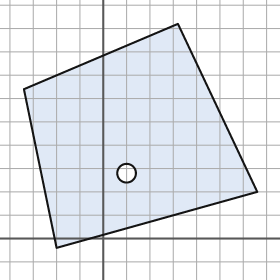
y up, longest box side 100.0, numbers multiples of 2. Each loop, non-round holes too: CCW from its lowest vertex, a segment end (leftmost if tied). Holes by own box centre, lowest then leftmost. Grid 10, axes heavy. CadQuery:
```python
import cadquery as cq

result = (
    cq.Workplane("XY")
    .moveTo(-20.0, -4.0)
    .lineTo(66.0, 20.0)
    .lineTo(32.0, 92.0)
    .lineTo(-34.0, 64.0)
    .close()
    .moveTo(10.0, 28.0)
    .circle(4.0)
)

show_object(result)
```